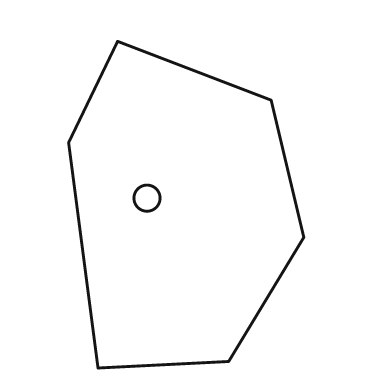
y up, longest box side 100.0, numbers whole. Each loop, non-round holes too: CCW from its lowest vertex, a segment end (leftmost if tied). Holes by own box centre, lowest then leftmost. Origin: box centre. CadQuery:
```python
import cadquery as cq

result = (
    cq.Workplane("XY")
    .moveTo(-27.0, -50.0)
    .lineTo(13.0, -48.0)
    .lineTo(36.0, -10.0)
    .lineTo(26.0, 32.0)
    .lineTo(-21.0, 50.0)
    .lineTo(-36.0, 19.0)
    .close()
    .moveTo(-12.0, 2.0)
    .circle(4.0)
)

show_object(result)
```